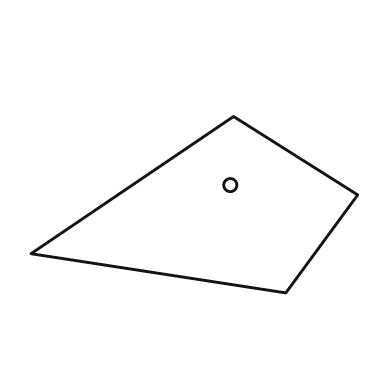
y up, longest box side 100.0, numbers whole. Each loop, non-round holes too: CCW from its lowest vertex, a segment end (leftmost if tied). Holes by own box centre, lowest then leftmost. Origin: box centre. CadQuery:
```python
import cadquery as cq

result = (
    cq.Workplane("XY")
    .moveTo(28.0, -27.0)
    .lineTo(50.0, 3.0)
    .lineTo(12.0, 27.0)
    .lineTo(-50.0, -15.0)
    .close()
    .moveTo(11.0, 6.0)
    .circle(2.0)
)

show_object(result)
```